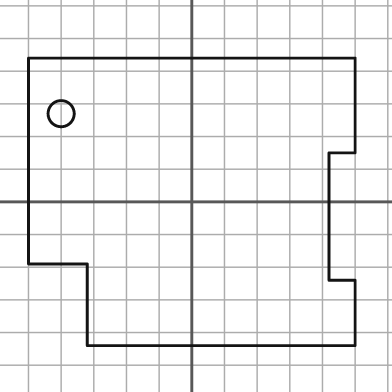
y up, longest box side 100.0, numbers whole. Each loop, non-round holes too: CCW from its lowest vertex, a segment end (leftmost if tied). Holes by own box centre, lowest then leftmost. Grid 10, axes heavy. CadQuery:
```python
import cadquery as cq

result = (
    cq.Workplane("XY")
    .moveTo(-32.0, -44.0)
    .lineTo(50.0, -44.0)
    .lineTo(50.0, -24.0)
    .lineTo(42.0, -24.0)
    .lineTo(42.0, 15.0)
    .lineTo(50.0, 15.0)
    .lineTo(50.0, 44.0)
    .lineTo(-50.0, 44.0)
    .lineTo(-50.0, -19.0)
    .lineTo(-32.0, -19.0)
    .close()
    .moveTo(-40.0, 27.0)
    .circle(4.0)
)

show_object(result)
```